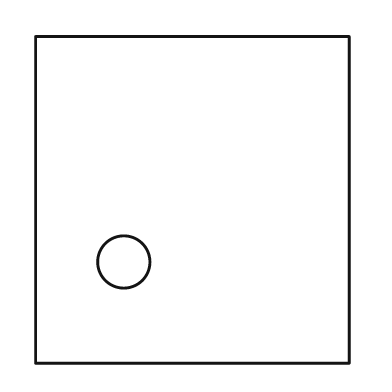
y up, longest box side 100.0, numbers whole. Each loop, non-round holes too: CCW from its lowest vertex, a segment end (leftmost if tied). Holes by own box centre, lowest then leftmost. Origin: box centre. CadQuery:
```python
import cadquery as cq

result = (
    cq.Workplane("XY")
    .moveTo(-48.0, -50.0)
    .lineTo(48.0, -50.0)
    .lineTo(48.0, 50.0)
    .lineTo(-48.0, 50.0)
    .close()
    .moveTo(-21.0, -19.0)
    .circle(8.0)
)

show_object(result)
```